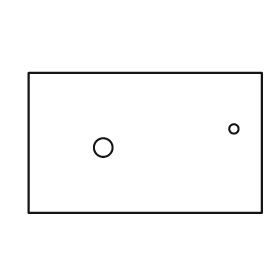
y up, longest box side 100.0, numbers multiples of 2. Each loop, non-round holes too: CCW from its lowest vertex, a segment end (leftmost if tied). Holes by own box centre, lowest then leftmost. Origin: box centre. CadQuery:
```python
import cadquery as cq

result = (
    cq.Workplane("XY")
    .moveTo(-50.0, -30.0)
    .lineTo(50.0, -30.0)
    .lineTo(50.0, 30.0)
    .lineTo(-50.0, 30.0)
    .close()
    .moveTo(-18.0, -2.0)
    .circle(4.0)
    .moveTo(38.0, 6.0)
    .circle(2.0)
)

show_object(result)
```